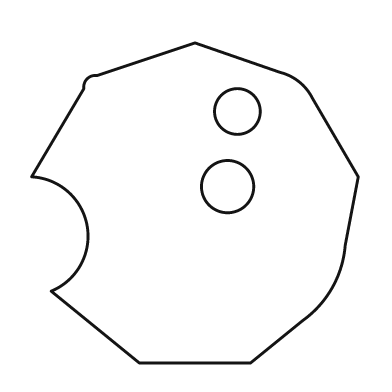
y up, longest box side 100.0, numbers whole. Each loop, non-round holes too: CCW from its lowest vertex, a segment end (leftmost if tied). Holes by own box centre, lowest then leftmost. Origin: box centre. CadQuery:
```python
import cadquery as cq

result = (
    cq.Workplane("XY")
    .moveTo(-17.0, -49.0)
    .lineTo(17.0, -49.0)
    .lineTo(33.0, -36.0)
    .threePointArc((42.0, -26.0), (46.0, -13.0))
    .lineTo(50.0, 8.0)
    .lineTo(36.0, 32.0)
    .threePointArc((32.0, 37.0), (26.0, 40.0))
    .lineTo(0.0, 49.0)
    .lineTo(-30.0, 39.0)
    .threePointArc((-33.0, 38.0), (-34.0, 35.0))
    .lineTo(-50.0, 8.0)
    .threePointArc((-33.0, -7.0), (-44.0, -27.0))
    .close()
    .moveTo(10.0, 5.0)
    .circle(8.0)
    .moveTo(13.0, 28.0)
    .circle(7.0)
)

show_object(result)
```